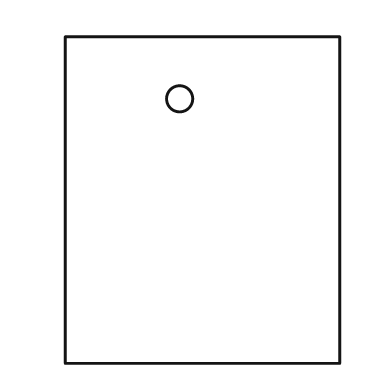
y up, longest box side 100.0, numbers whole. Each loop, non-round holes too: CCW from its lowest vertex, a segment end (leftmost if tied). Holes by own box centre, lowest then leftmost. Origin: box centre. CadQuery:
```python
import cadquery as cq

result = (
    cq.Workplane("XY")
    .moveTo(-42.0, -50.0)
    .lineTo(42.0, -50.0)
    .lineTo(42.0, 50.0)
    .lineTo(-42.0, 50.0)
    .close()
    .moveTo(-7.0, 31.0)
    .circle(4.0)
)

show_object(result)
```